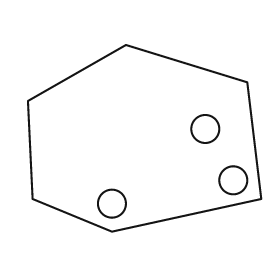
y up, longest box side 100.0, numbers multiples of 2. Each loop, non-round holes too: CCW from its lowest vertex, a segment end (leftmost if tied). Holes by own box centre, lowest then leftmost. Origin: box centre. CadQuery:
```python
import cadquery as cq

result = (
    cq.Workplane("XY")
    .moveTo(-14.0, -40.0)
    .lineTo(50.0, -26.0)
    .lineTo(44.0, 24.0)
    .lineTo(-8.0, 40.0)
    .lineTo(-50.0, 16.0)
    .lineTo(-48.0, -26.0)
    .close()
    .moveTo(-14.0, -28.0)
    .circle(6.0)
    .moveTo(38.0, -18.0)
    .circle(6.0)
    .moveTo(26.0, 4.0)
    .circle(6.0)
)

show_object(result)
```